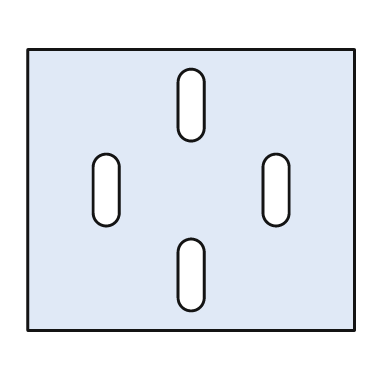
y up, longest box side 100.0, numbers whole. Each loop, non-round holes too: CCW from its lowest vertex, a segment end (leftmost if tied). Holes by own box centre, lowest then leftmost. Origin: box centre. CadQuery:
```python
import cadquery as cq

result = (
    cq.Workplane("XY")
    .moveTo(-50.0, -43.0)
    .lineTo(50.0, -43.0)
    .lineTo(50.0, 43.0)
    .lineTo(-50.0, 43.0)
    .close()
    .moveTo(-4.0, -33.0)
    .threePointArc((0.0, -37.0), (4.0, -33.0))
    .lineTo(4.0, -19.0)
    .threePointArc((0.0, -15.0), (-4.0, -19.0))
    .close()
    .moveTo(-30.0, -7.0)
    .threePointArc((-26.0, -11.0), (-22.0, -7.0))
    .lineTo(-22.0, 7.0)
    .threePointArc((-26.0, 11.0), (-30.0, 7.0))
    .close()
    .moveTo(22.0, -7.0)
    .threePointArc((26.0, -11.0), (30.0, -7.0))
    .lineTo(30.0, 7.0)
    .threePointArc((26.0, 11.0), (22.0, 7.0))
    .close()
    .moveTo(-4.0, 19.0)
    .threePointArc((0.0, 15.0), (4.0, 19.0))
    .lineTo(4.0, 33.0)
    .threePointArc((0.0, 37.0), (-4.0, 33.0))
    .close()
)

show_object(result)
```